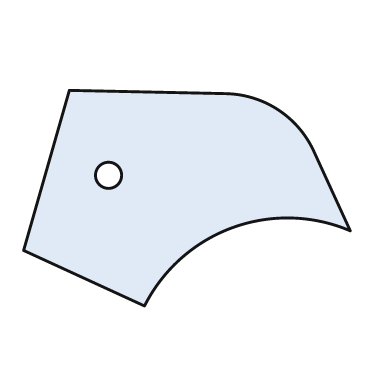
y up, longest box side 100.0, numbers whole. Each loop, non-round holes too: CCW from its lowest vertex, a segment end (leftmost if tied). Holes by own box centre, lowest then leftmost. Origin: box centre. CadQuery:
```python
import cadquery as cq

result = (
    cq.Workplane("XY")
    .moveTo(-13.0, -33.0)
    .threePointArc((14.0, -9.0), (50.0, -10.0))
    .lineTo(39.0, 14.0)
    .threePointArc((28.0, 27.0), (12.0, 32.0))
    .lineTo(-36.0, 33.0)
    .lineTo(-50.0, -16.0)
    .close()
    .moveTo(-24.0, 7.0)
    .circle(4.0)
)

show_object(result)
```